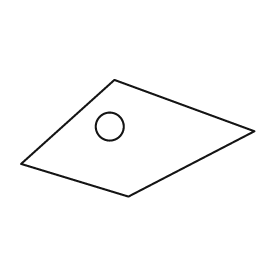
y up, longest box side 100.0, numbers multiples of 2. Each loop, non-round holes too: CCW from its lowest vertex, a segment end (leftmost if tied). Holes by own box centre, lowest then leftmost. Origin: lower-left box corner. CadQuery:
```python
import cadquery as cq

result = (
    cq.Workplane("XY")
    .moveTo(46.0, 0.0)
    .lineTo(100.0, 28.0)
    .lineTo(40.0, 50.0)
    .lineTo(0.0, 14.0)
    .close()
    .moveTo(38.0, 30.0)
    .circle(6.0)
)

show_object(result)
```